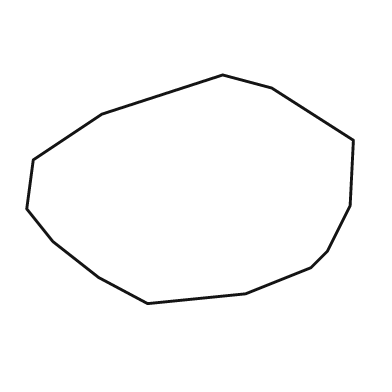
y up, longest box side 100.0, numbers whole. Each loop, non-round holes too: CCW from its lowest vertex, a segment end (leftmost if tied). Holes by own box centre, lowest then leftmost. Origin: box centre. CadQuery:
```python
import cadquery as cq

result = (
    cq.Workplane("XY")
    .moveTo(-13.0, -35.0)
    .lineTo(17.0, -32.0)
    .lineTo(37.0, -24.0)
    .lineTo(42.0, -19.0)
    .lineTo(49.0, -5.0)
    .lineTo(50.0, 15.0)
    .lineTo(25.0, 31.0)
    .lineTo(10.0, 35.0)
    .lineTo(-27.0, 23.0)
    .lineTo(-48.0, 9.0)
    .lineTo(-50.0, -6.0)
    .lineTo(-42.0, -16.0)
    .lineTo(-28.0, -27.0)
    .close()
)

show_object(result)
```